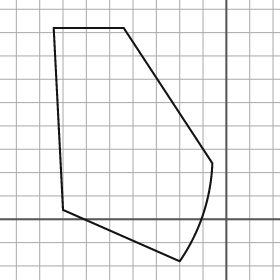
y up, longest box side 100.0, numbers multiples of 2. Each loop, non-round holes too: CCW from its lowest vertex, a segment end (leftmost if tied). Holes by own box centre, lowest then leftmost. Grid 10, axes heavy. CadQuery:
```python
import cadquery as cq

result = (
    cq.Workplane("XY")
    .moveTo(-20.0, -18.0)
    .threePointArc((-10.0, 2.0), (-6.0, 24.0))
    .lineTo(-44.0, 82.0)
    .lineTo(-74.0, 82.0)
    .lineTo(-70.0, 4.0)
    .close()
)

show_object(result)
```